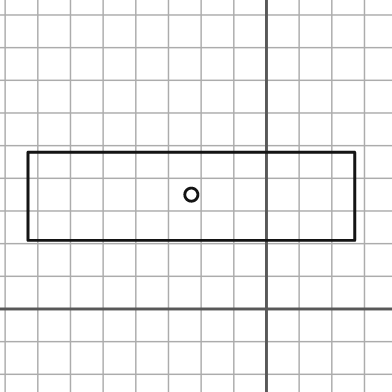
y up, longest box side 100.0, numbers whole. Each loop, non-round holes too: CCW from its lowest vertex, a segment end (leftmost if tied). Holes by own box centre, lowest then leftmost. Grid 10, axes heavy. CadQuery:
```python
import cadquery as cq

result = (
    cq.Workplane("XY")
    .moveTo(-73.0, 21.0)
    .lineTo(27.0, 21.0)
    .lineTo(27.0, 48.0)
    .lineTo(-73.0, 48.0)
    .close()
    .moveTo(-23.0, 35.0)
    .circle(2.0)
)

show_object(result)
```